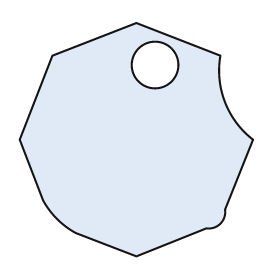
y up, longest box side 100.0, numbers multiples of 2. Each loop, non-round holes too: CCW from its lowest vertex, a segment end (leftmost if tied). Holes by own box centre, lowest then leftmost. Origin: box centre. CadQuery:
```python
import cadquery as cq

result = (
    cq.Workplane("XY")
    .moveTo(0.0, -50.0)
    .lineTo(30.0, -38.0)
    .threePointArc((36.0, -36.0), (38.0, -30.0))
    .lineTo(50.0, 0.0)
    .threePointArc((38.0, 16.0), (36.0, 36.0))
    .lineTo(0.0, 50.0)
    .lineTo(-36.0, 36.0)
    .lineTo(-50.0, 0.0)
    .lineTo(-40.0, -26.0)
    .threePointArc((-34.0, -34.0), (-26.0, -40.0))
    .close()
    .moveTo(8.0, 32.0)
    .circle(10.0)
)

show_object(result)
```